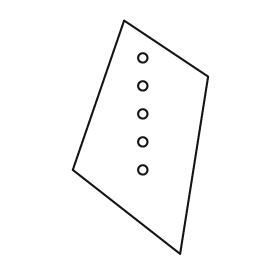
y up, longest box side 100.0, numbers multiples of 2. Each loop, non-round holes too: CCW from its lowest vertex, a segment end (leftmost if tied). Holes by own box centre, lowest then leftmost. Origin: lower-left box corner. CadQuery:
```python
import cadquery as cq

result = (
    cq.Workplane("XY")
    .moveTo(46.0, 0.0)
    .lineTo(58.0, 76.0)
    .lineTo(22.0, 100.0)
    .lineTo(0.0, 36.0)
    .close()
    .moveTo(30.0, 36.0)
    .circle(2.0)
    .moveTo(30.0, 48.0)
    .circle(2.0)
    .moveTo(30.0, 60.0)
    .circle(2.0)
    .moveTo(30.0, 72.0)
    .circle(2.0)
    .moveTo(30.0, 84.0)
    .circle(2.0)
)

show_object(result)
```